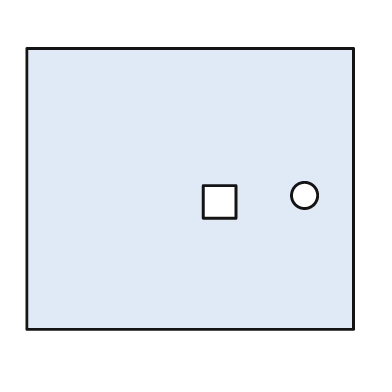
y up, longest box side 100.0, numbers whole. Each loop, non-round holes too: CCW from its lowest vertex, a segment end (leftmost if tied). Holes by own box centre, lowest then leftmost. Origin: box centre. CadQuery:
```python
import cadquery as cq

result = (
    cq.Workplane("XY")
    .moveTo(-50.0, -43.0)
    .lineTo(50.0, -43.0)
    .lineTo(50.0, 43.0)
    .lineTo(-50.0, 43.0)
    .close()
    .moveTo(4.0, -9.0)
    .lineTo(14.0, -9.0)
    .lineTo(14.0, 1.0)
    .lineTo(4.0, 1.0)
    .close()
    .moveTo(35.0, -2.0)
    .circle(4.0)
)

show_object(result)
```